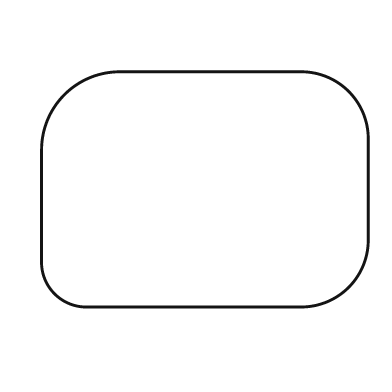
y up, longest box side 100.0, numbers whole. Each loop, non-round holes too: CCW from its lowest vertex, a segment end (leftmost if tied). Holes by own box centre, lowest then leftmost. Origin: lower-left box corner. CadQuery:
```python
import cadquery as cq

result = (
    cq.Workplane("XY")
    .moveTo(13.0, 0.0)
    .lineTo(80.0, 0.0)
    .threePointArc((94.0, 6.0), (100.0, 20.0))
    .lineTo(100.0, 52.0)
    .threePointArc((94.0, 66.0), (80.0, 72.0))
    .lineTo(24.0, 72.0)
    .threePointArc((7.0, 65.0), (0.0, 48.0))
    .lineTo(0.0, 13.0)
    .threePointArc((4.0, 4.0), (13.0, 0.0))
    .close()
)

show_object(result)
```